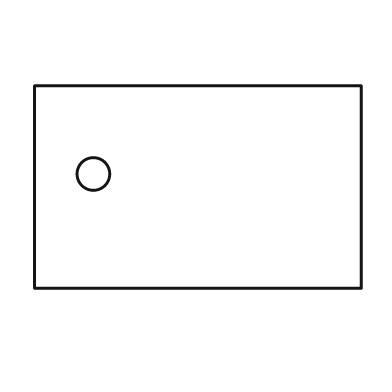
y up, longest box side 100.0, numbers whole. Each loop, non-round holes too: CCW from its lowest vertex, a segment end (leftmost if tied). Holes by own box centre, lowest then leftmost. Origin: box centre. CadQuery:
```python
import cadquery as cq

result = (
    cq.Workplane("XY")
    .moveTo(-50.0, -31.0)
    .lineTo(50.0, -31.0)
    .lineTo(50.0, 31.0)
    .lineTo(-50.0, 31.0)
    .close()
    .moveTo(-32.0, 4.0)
    .circle(5.0)
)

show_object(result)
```